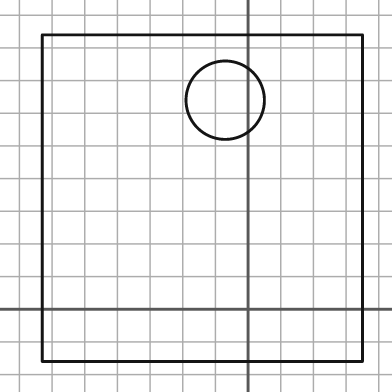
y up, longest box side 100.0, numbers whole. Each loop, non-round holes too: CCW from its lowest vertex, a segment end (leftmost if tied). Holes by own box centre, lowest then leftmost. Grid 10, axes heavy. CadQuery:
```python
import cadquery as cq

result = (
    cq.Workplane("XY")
    .moveTo(-63.0, -16.0)
    .lineTo(35.0, -16.0)
    .lineTo(35.0, 84.0)
    .lineTo(-63.0, 84.0)
    .close()
    .moveTo(-7.0, 64.0)
    .circle(12.0)
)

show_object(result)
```